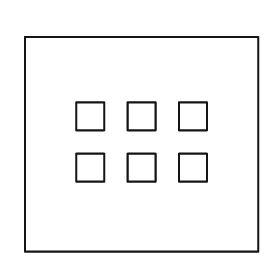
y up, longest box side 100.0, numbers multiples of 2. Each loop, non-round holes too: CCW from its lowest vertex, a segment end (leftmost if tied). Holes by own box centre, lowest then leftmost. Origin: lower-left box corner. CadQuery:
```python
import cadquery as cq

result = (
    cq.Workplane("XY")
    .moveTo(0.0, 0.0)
    .lineTo(100.0, 0.0)
    .lineTo(100.0, 92.0)
    .lineTo(0.0, 92.0)
    .close()
    .moveTo(22.0, 30.0)
    .lineTo(34.0, 30.0)
    .lineTo(34.0, 42.0)
    .lineTo(22.0, 42.0)
    .close()
    .moveTo(44.0, 30.0)
    .lineTo(56.0, 30.0)
    .lineTo(56.0, 42.0)
    .lineTo(44.0, 42.0)
    .close()
    .moveTo(66.0, 30.0)
    .lineTo(78.0, 30.0)
    .lineTo(78.0, 42.0)
    .lineTo(66.0, 42.0)
    .close()
    .moveTo(22.0, 52.0)
    .lineTo(34.0, 52.0)
    .lineTo(34.0, 64.0)
    .lineTo(22.0, 64.0)
    .close()
    .moveTo(44.0, 52.0)
    .lineTo(56.0, 52.0)
    .lineTo(56.0, 64.0)
    .lineTo(44.0, 64.0)
    .close()
    .moveTo(66.0, 52.0)
    .lineTo(78.0, 52.0)
    .lineTo(78.0, 64.0)
    .lineTo(66.0, 64.0)
    .close()
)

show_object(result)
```